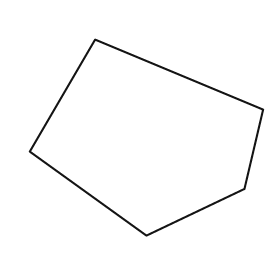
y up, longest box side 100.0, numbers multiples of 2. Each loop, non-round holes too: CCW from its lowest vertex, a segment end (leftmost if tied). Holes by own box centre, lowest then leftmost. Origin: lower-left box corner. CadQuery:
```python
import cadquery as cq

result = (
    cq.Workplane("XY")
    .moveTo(50.0, 0.0)
    .lineTo(92.0, 20.0)
    .lineTo(100.0, 54.0)
    .lineTo(28.0, 84.0)
    .lineTo(0.0, 36.0)
    .close()
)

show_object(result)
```